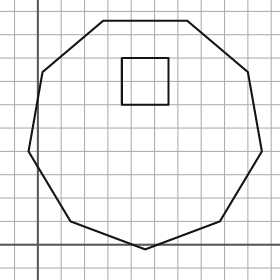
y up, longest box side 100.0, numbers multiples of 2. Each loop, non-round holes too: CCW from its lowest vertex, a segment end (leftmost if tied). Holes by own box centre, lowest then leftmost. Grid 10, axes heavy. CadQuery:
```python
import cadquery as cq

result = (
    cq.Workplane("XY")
    .moveTo(46.0, -2.0)
    .lineTo(78.0, 10.0)
    .lineTo(96.0, 40.0)
    .lineTo(90.0, 74.0)
    .lineTo(64.0, 96.0)
    .lineTo(28.0, 96.0)
    .lineTo(2.0, 74.0)
    .lineTo(-4.0, 40.0)
    .lineTo(14.0, 10.0)
    .close()
    .moveTo(36.0, 60.0)
    .lineTo(56.0, 60.0)
    .lineTo(56.0, 80.0)
    .lineTo(36.0, 80.0)
    .close()
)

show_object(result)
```